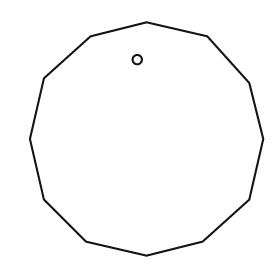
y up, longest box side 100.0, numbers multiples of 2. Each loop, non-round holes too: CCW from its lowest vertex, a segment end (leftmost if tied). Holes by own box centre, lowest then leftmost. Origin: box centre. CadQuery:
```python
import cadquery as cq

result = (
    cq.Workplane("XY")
    .moveTo(0.0, -50.0)
    .lineTo(24.0, -44.0)
    .lineTo(44.0, -26.0)
    .lineTo(50.0, 0.0)
    .lineTo(44.0, 24.0)
    .lineTo(26.0, 44.0)
    .lineTo(0.0, 50.0)
    .lineTo(-24.0, 44.0)
    .lineTo(-44.0, 26.0)
    .lineTo(-50.0, 0.0)
    .lineTo(-44.0, -26.0)
    .lineTo(-26.0, -44.0)
    .close()
    .moveTo(-4.0, 34.0)
    .circle(2.0)
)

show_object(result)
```